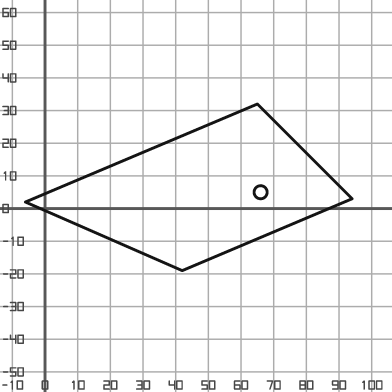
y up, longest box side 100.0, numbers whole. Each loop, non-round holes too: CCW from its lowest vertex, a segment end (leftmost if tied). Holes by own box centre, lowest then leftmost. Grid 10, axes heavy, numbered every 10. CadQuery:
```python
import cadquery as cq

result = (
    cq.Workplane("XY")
    .moveTo(42.0, -19.0)
    .lineTo(94.0, 3.0)
    .lineTo(65.0, 32.0)
    .lineTo(-6.0, 2.0)
    .close()
    .moveTo(66.0, 5.0)
    .circle(2.0)
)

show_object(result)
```